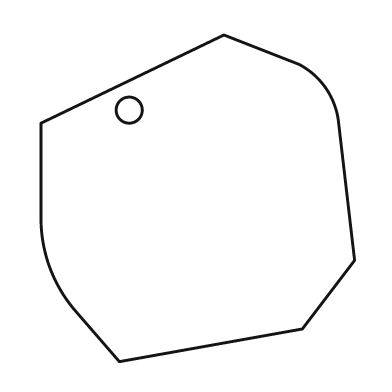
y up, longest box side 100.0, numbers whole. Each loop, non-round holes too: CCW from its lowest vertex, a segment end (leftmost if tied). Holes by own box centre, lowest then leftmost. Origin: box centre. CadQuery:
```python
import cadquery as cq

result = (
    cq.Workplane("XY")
    .moveTo(-24.0, -50.0)
    .lineTo(32.0, -40.0)
    .lineTo(48.0, -19.0)
    .lineTo(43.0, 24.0)
    .threePointArc((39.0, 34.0), (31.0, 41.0))
    .lineTo(8.0, 50.0)
    .lineTo(-48.0, 23.0)
    .lineTo(-48.0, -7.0)
    .threePointArc((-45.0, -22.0), (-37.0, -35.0))
    .close()
    .moveTo(-21.0, 27.0)
    .circle(4.0)
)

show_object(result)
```